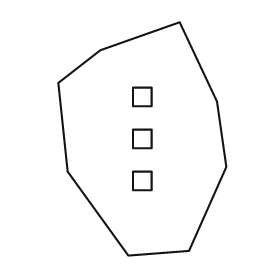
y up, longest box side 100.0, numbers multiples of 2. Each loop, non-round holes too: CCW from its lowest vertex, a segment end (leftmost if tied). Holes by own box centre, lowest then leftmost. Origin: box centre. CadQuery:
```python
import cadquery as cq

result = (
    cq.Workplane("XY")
    .moveTo(-6.0, -50.0)
    .lineTo(20.0, -48.0)
    .lineTo(36.0, -12.0)
    .lineTo(32.0, 16.0)
    .lineTo(16.0, 50.0)
    .lineTo(-18.0, 38.0)
    .lineTo(-36.0, 24.0)
    .lineTo(-32.0, -14.0)
    .close()
    .moveTo(-4.0, -22.0)
    .lineTo(4.0, -22.0)
    .lineTo(4.0, -14.0)
    .lineTo(-4.0, -14.0)
    .close()
    .moveTo(-4.0, -4.0)
    .lineTo(4.0, -4.0)
    .lineTo(4.0, 4.0)
    .lineTo(-4.0, 4.0)
    .close()
    .moveTo(-4.0, 14.0)
    .lineTo(4.0, 14.0)
    .lineTo(4.0, 22.0)
    .lineTo(-4.0, 22.0)
    .close()
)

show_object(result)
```